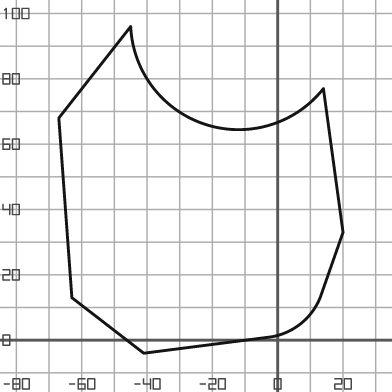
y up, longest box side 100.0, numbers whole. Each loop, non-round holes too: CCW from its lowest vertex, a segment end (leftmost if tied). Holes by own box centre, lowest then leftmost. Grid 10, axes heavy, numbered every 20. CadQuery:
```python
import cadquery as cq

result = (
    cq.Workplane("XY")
    .moveTo(-41.0, -4.0)
    .lineTo(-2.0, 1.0)
    .threePointArc((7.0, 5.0), (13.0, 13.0))
    .lineTo(20.0, 33.0)
    .lineTo(14.0, 77.0)
    .threePointArc((-22.0, 66.0), (-45.0, 96.0))
    .lineTo(-67.0, 68.0)
    .lineTo(-63.0, 13.0)
    .close()
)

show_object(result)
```